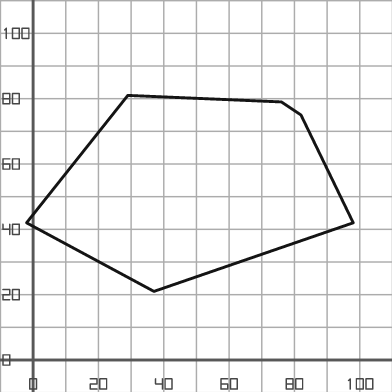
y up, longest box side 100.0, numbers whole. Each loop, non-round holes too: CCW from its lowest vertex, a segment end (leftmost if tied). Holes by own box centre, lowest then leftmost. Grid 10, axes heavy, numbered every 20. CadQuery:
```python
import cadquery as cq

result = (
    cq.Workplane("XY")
    .moveTo(37.0, 21.0)
    .lineTo(98.0, 42.0)
    .lineTo(82.0, 75.0)
    .lineTo(76.0, 79.0)
    .lineTo(29.0, 81.0)
    .lineTo(-2.0, 42.0)
    .close()
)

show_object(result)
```